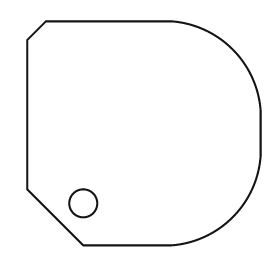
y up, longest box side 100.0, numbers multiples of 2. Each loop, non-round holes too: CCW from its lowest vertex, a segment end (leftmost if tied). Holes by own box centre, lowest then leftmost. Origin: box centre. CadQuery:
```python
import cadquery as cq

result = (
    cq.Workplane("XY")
    .moveTo(-26.0, -48.0)
    .lineTo(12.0, -48.0)
    .threePointArc((38.0, -36.0), (50.0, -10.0))
    .lineTo(50.0, 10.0)
    .threePointArc((38.0, 36.0), (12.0, 48.0))
    .lineTo(-42.0, 48.0)
    .lineTo(-50.0, 40.0)
    .lineTo(-50.0, -24.0)
    .close()
    .moveTo(-26.0, -30.0)
    .circle(6.0)
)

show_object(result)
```